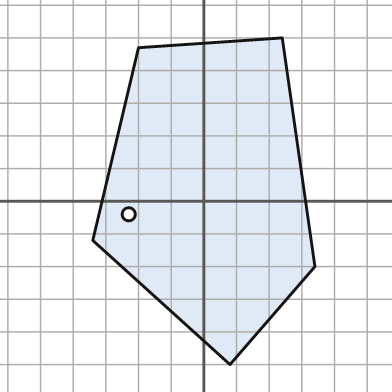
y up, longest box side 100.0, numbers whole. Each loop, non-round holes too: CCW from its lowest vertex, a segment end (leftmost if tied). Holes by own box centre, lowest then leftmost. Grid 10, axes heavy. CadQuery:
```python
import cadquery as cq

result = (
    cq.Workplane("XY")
    .moveTo(8.0, -50.0)
    .lineTo(34.0, -20.0)
    .lineTo(24.0, 50.0)
    .lineTo(-20.0, 47.0)
    .lineTo(-34.0, -12.0)
    .close()
    .moveTo(-23.0, -4.0)
    .circle(2.0)
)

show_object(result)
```